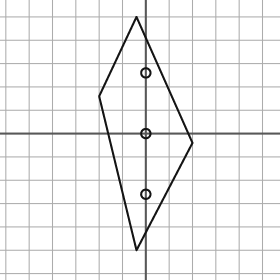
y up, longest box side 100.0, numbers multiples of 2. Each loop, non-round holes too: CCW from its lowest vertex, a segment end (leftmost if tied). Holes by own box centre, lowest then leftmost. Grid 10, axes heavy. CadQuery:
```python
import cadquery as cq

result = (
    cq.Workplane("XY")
    .moveTo(-4.0, -50.0)
    .lineTo(20.0, -4.0)
    .lineTo(-4.0, 50.0)
    .lineTo(-20.0, 16.0)
    .close()
    .moveTo(0.0, -26.0)
    .circle(2.0)
    .moveTo(0.0, 0.0)
    .circle(2.0)
    .moveTo(0.0, 26.0)
    .circle(2.0)
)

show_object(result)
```